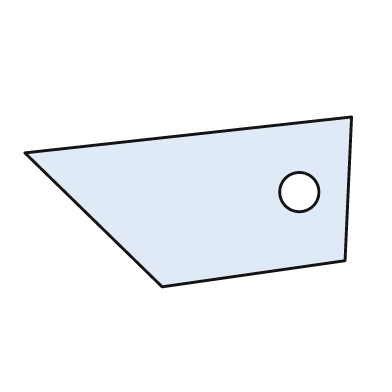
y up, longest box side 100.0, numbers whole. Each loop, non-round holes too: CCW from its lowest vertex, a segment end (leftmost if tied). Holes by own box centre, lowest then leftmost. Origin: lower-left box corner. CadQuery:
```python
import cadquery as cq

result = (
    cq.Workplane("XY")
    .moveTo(42.0, 0.0)
    .lineTo(98.0, 8.0)
    .lineTo(100.0, 52.0)
    .lineTo(0.0, 41.0)
    .close()
    .moveTo(84.0, 29.0)
    .circle(6.0)
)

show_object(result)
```